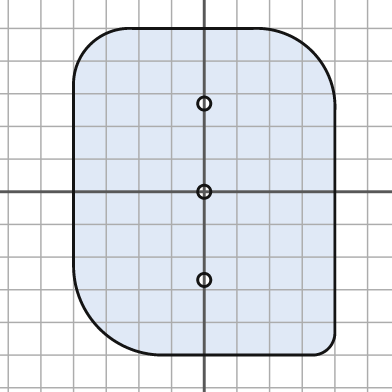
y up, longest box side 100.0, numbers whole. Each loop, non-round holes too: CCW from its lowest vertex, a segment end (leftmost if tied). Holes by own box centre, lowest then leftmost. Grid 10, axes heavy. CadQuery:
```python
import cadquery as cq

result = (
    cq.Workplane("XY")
    .moveTo(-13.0, -50.0)
    .lineTo(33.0, -50.0)
    .threePointArc((38.0, -48.0), (40.0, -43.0))
    .lineTo(40.0, 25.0)
    .threePointArc((33.0, 43.0), (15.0, 50.0))
    .lineTo(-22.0, 50.0)
    .threePointArc((-35.0, 45.0), (-40.0, 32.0))
    .lineTo(-40.0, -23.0)
    .threePointArc((-32.0, -42.0), (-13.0, -50.0))
    .close()
    .moveTo(0.0, -27.0)
    .circle(2.0)
    .moveTo(0.0, 0.0)
    .circle(2.0)
    .moveTo(0.0, 27.0)
    .circle(2.0)
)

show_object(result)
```